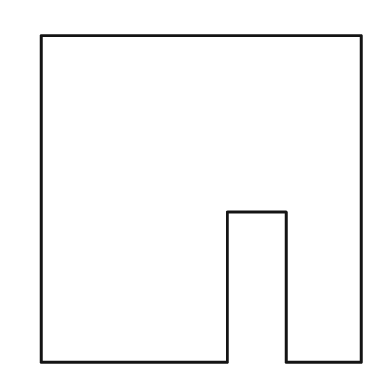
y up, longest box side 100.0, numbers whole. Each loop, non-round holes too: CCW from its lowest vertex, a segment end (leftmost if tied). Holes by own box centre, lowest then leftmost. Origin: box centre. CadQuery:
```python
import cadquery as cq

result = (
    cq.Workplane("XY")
    .moveTo(-49.0, -50.0)
    .lineTo(8.0, -50.0)
    .lineTo(8.0, -4.0)
    .lineTo(26.0, -4.0)
    .lineTo(26.0, -50.0)
    .lineTo(49.0, -50.0)
    .lineTo(49.0, 50.0)
    .lineTo(-49.0, 50.0)
    .close()
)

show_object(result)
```